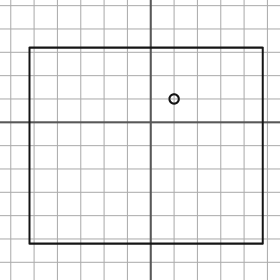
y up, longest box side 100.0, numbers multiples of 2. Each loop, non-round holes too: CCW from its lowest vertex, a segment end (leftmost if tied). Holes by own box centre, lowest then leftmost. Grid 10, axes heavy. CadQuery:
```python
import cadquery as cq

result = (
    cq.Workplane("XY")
    .moveTo(-52.0, -52.0)
    .lineTo(48.0, -52.0)
    .lineTo(48.0, 32.0)
    .lineTo(-52.0, 32.0)
    .close()
    .moveTo(10.0, 10.0)
    .circle(2.0)
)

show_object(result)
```